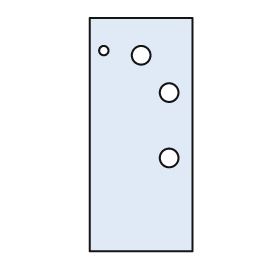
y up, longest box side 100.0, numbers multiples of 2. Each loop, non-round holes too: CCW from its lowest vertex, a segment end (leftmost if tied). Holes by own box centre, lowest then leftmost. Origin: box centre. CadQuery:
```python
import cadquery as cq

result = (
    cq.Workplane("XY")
    .moveTo(-22.0, -50.0)
    .lineTo(22.0, -50.0)
    .lineTo(22.0, 50.0)
    .lineTo(-22.0, 50.0)
    .close()
    .moveTo(12.0, -10.0)
    .circle(4.0)
    .moveTo(12.0, 18.0)
    .circle(4.0)
    .moveTo(0.0, 34.0)
    .circle(4.0)
    .moveTo(-16.0, 36.0)
    .circle(2.0)
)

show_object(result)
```